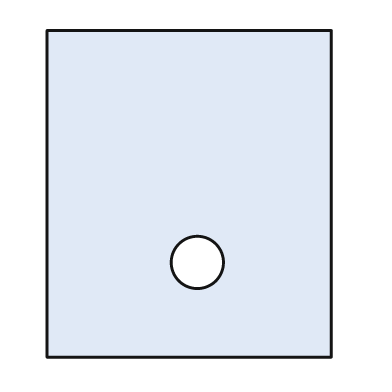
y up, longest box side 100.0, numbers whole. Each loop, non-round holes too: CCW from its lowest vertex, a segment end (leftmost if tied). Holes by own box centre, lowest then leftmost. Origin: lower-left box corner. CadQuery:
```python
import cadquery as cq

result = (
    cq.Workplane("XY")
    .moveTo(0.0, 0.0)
    .lineTo(87.0, 0.0)
    .lineTo(87.0, 100.0)
    .lineTo(0.0, 100.0)
    .close()
    .moveTo(46.0, 29.0)
    .circle(8.0)
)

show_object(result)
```